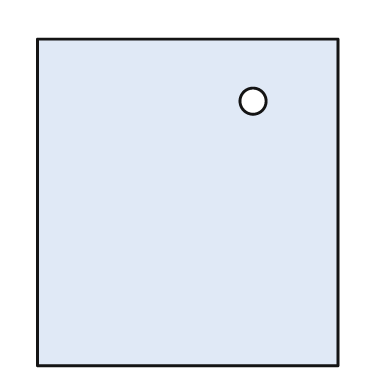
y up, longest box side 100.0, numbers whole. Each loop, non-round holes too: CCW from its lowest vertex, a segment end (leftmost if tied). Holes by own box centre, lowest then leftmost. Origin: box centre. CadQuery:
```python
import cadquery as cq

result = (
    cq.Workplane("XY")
    .moveTo(-46.0, -50.0)
    .lineTo(46.0, -50.0)
    .lineTo(46.0, 50.0)
    .lineTo(-46.0, 50.0)
    .close()
    .moveTo(20.0, 31.0)
    .circle(4.0)
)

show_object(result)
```